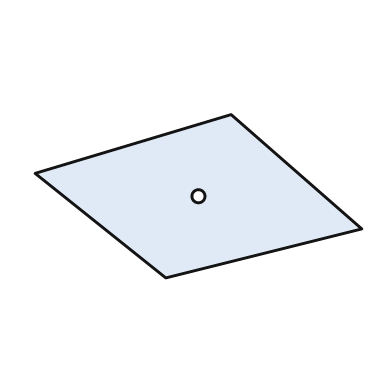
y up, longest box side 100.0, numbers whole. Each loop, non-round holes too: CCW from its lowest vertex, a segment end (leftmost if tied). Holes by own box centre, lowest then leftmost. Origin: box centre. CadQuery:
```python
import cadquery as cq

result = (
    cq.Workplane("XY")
    .moveTo(-10.0, -25.0)
    .lineTo(50.0, -10.0)
    .lineTo(10.0, 25.0)
    .lineTo(-50.0, 7.0)
    .close()
    .moveTo(0.0, 0.0)
    .circle(2.0)
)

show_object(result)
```